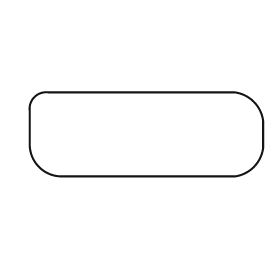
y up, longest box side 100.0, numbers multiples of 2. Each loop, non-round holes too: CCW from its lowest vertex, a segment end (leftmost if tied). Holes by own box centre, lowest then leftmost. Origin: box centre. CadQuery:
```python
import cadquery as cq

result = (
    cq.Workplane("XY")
    .moveTo(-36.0, -18.0)
    .lineTo(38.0, -18.0)
    .threePointArc((46.0, -14.0), (50.0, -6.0))
    .lineTo(50.0, 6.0)
    .threePointArc((46.0, 14.0), (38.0, 18.0))
    .lineTo(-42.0, 18.0)
    .threePointArc((-48.0, 16.0), (-50.0, 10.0))
    .lineTo(-50.0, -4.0)
    .threePointArc((-46.0, -14.0), (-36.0, -18.0))
    .close()
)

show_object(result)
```